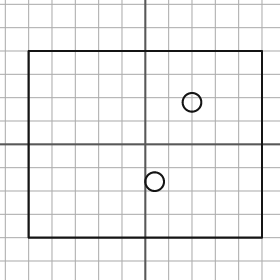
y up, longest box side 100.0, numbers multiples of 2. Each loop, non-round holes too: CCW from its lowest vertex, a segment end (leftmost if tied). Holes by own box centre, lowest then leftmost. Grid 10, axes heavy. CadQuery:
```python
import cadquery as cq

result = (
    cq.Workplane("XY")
    .moveTo(-50.0, -40.0)
    .lineTo(50.0, -40.0)
    .lineTo(50.0, 40.0)
    .lineTo(-50.0, 40.0)
    .close()
    .moveTo(4.0, -16.0)
    .circle(4.0)
    .moveTo(20.0, 18.0)
    .circle(4.0)
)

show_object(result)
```